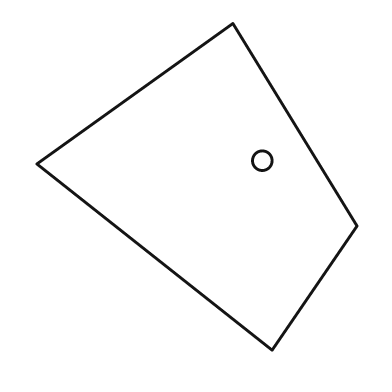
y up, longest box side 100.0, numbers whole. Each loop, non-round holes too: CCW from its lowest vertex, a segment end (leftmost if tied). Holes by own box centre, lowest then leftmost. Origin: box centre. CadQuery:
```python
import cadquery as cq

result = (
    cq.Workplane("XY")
    .moveTo(23.0, -50.0)
    .lineTo(49.0, -12.0)
    .lineTo(11.0, 50.0)
    .lineTo(-49.0, 7.0)
    .close()
    .moveTo(20.0, 8.0)
    .circle(3.0)
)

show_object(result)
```